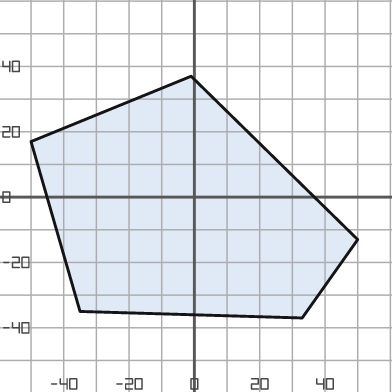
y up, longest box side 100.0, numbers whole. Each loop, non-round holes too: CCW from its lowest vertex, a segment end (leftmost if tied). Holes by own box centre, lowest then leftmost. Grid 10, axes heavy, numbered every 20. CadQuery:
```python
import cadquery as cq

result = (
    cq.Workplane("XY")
    .moveTo(33.0, -37.0)
    .lineTo(50.0, -13.0)
    .lineTo(-1.0, 37.0)
    .lineTo(-50.0, 17.0)
    .lineTo(-35.0, -35.0)
    .close()
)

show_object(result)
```